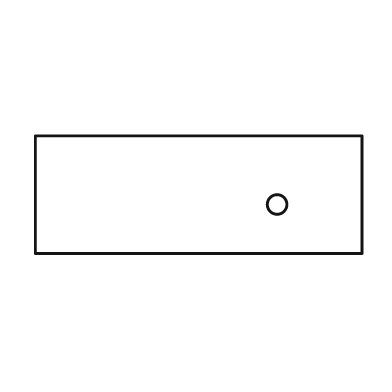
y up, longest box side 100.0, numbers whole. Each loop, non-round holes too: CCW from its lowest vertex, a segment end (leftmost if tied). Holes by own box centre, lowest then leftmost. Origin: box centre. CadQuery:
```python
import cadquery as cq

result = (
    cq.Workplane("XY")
    .moveTo(-50.0, -18.0)
    .lineTo(50.0, -18.0)
    .lineTo(50.0, 18.0)
    .lineTo(-50.0, 18.0)
    .close()
    .moveTo(24.0, -3.0)
    .circle(3.0)
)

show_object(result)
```